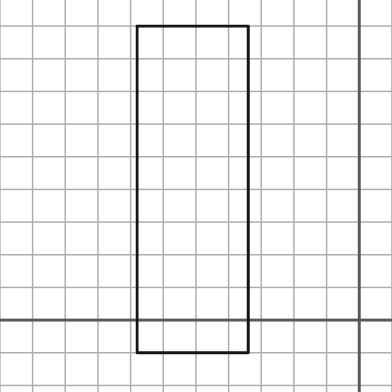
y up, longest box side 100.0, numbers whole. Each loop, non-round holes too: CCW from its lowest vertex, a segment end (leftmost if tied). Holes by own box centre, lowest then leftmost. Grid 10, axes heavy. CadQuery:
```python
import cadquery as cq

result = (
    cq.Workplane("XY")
    .moveTo(-68.0, -10.0)
    .lineTo(-34.0, -10.0)
    .lineTo(-34.0, 90.0)
    .lineTo(-68.0, 90.0)
    .close()
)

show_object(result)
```